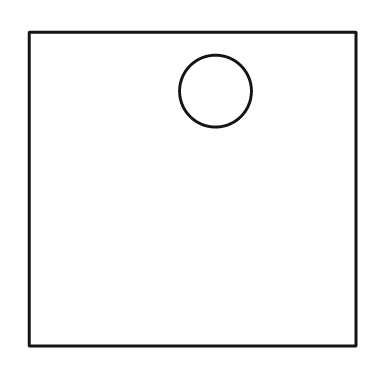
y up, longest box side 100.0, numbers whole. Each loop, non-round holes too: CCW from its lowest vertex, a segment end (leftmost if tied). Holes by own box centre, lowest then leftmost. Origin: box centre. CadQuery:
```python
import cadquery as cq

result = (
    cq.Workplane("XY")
    .moveTo(-50.0, -48.0)
    .lineTo(50.0, -48.0)
    .lineTo(50.0, 48.0)
    .lineTo(-50.0, 48.0)
    .close()
    .moveTo(7.0, 30.0)
    .circle(11.0)
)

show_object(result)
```